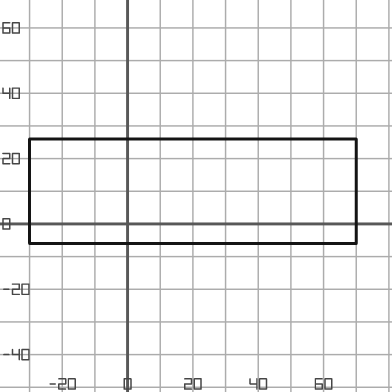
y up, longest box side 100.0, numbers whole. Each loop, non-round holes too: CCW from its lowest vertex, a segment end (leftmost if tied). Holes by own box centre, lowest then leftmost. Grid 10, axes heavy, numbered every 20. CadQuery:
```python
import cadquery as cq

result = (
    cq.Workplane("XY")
    .moveTo(-30.0, -6.0)
    .lineTo(70.0, -6.0)
    .lineTo(70.0, 26.0)
    .lineTo(-30.0, 26.0)
    .close()
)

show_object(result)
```